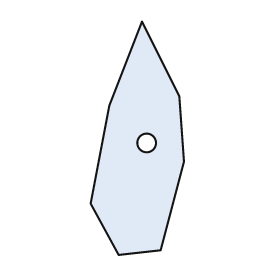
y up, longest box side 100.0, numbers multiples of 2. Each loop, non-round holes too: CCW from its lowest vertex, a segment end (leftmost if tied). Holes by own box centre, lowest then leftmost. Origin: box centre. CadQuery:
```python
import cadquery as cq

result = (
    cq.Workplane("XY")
    .moveTo(-8.0, -50.0)
    .lineTo(10.0, -48.0)
    .lineTo(20.0, -10.0)
    .lineTo(18.0, 18.0)
    .lineTo(2.0, 50.0)
    .lineTo(-12.0, 14.0)
    .lineTo(-20.0, -28.0)
    .close()
    .moveTo(4.0, -2.0)
    .circle(4.0)
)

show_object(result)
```